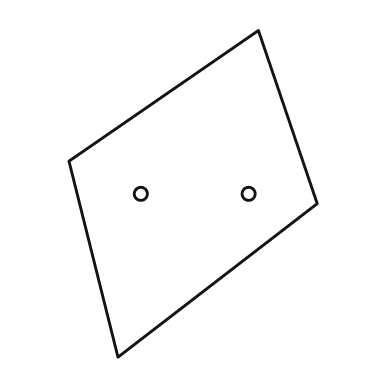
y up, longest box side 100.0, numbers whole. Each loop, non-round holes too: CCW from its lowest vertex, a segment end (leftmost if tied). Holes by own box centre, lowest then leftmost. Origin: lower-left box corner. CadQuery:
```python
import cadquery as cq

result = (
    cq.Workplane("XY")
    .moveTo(15.0, 0.0)
    .lineTo(76.0, 47.0)
    .lineTo(58.0, 100.0)
    .lineTo(0.0, 60.0)
    .close()
    .moveTo(22.0, 50.0)
    .circle(2.0)
    .moveTo(55.0, 50.0)
    .circle(2.0)
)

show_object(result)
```